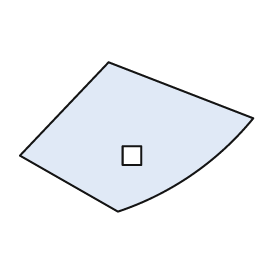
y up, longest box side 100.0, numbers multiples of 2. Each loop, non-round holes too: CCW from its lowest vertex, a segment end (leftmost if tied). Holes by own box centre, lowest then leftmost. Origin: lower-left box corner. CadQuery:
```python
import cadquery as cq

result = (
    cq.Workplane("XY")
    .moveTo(42.0, 0.0)
    .threePointArc((74.0, 16.0), (100.0, 40.0))
    .lineTo(38.0, 64.0)
    .lineTo(0.0, 24.0)
    .close()
    .moveTo(44.0, 20.0)
    .lineTo(52.0, 20.0)
    .lineTo(52.0, 28.0)
    .lineTo(44.0, 28.0)
    .close()
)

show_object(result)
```